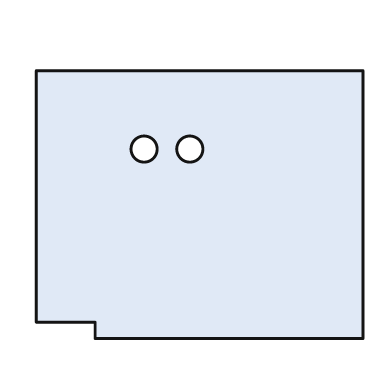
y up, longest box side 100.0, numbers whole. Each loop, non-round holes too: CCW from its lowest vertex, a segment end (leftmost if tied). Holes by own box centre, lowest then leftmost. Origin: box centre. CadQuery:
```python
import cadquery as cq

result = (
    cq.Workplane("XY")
    .moveTo(-32.0, -41.0)
    .lineTo(50.0, -41.0)
    .lineTo(50.0, 41.0)
    .lineTo(-50.0, 41.0)
    .lineTo(-50.0, -36.0)
    .lineTo(-32.0, -36.0)
    .close()
    .moveTo(-17.0, 17.0)
    .circle(4.0)
    .moveTo(-3.0, 17.0)
    .circle(4.0)
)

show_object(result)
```